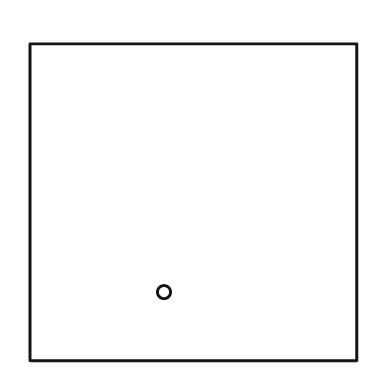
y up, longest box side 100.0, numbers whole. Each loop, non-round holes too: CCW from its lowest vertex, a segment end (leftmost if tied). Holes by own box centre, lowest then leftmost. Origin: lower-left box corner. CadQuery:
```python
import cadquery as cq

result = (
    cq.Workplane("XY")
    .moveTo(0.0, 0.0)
    .lineTo(100.0, 0.0)
    .lineTo(100.0, 97.0)
    .lineTo(0.0, 97.0)
    .close()
    .moveTo(41.0, 21.0)
    .circle(2.0)
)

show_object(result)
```